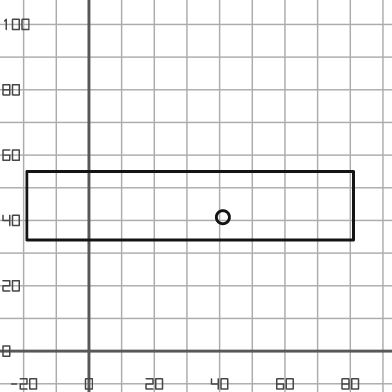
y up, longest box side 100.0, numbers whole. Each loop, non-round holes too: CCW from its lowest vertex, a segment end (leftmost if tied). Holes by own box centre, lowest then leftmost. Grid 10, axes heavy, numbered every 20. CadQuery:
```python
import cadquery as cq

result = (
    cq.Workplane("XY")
    .moveTo(-19.0, 34.0)
    .lineTo(81.0, 34.0)
    .lineTo(81.0, 55.0)
    .lineTo(-19.0, 55.0)
    .close()
    .moveTo(41.0, 41.0)
    .circle(2.0)
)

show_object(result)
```